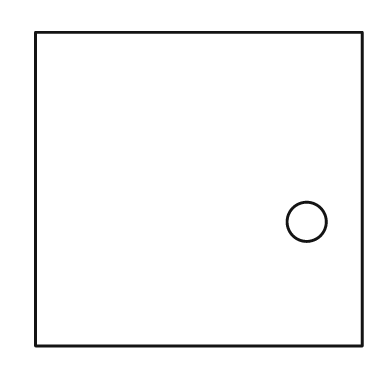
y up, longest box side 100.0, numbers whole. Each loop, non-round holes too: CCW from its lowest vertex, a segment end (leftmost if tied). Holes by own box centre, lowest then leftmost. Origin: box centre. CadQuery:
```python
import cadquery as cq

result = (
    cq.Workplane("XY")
    .moveTo(-50.0, -48.0)
    .lineTo(50.0, -48.0)
    .lineTo(50.0, 48.0)
    .lineTo(-50.0, 48.0)
    .close()
    .moveTo(33.0, -10.0)
    .circle(6.0)
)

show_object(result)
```